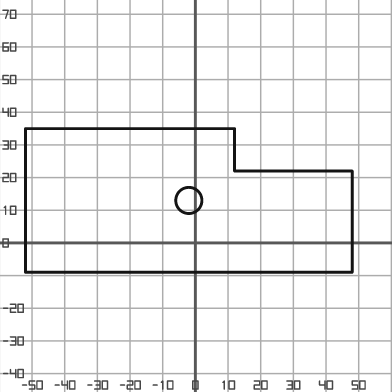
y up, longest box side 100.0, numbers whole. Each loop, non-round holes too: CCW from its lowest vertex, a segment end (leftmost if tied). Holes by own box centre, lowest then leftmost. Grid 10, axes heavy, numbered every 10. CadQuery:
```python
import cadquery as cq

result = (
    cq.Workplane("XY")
    .moveTo(-52.0, -9.0)
    .lineTo(48.0, -9.0)
    .lineTo(48.0, 22.0)
    .lineTo(12.0, 22.0)
    .lineTo(12.0, 35.0)
    .lineTo(-52.0, 35.0)
    .close()
    .moveTo(-2.0, 13.0)
    .circle(4.0)
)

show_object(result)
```